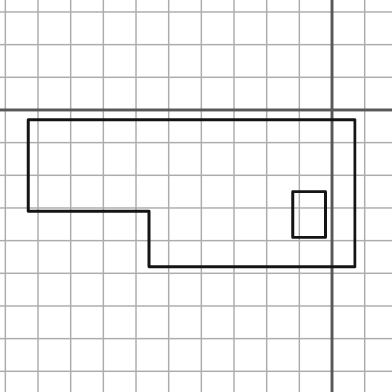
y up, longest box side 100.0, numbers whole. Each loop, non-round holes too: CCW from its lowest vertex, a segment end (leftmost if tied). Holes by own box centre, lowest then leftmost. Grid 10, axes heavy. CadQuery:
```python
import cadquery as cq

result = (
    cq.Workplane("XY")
    .moveTo(-56.0, -48.0)
    .lineTo(7.0, -48.0)
    .lineTo(7.0, -3.0)
    .lineTo(-93.0, -3.0)
    .lineTo(-93.0, -31.0)
    .lineTo(-56.0, -31.0)
    .close()
    .moveTo(-12.0, -39.0)
    .lineTo(-2.0, -39.0)
    .lineTo(-2.0, -25.0)
    .lineTo(-12.0, -25.0)
    .close()
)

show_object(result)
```